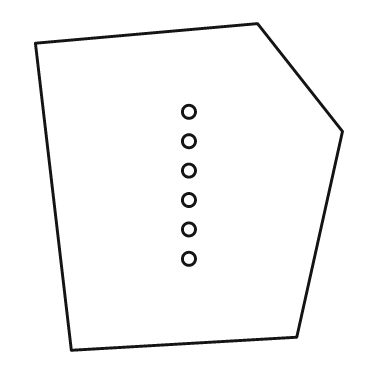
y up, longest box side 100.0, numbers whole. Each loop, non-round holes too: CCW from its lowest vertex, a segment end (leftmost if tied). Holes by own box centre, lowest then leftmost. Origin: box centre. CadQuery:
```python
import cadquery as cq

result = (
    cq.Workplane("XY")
    .moveTo(-36.0, -50.0)
    .lineTo(33.0, -46.0)
    .lineTo(47.0, 17.0)
    .lineTo(21.0, 50.0)
    .lineTo(-47.0, 44.0)
    .close()
    .moveTo(0.0, -22.0)
    .circle(2.0)
    .moveTo(0.0, -13.0)
    .circle(2.0)
    .moveTo(0.0, -4.0)
    .circle(2.0)
    .moveTo(0.0, 5.0)
    .circle(2.0)
    .moveTo(0.0, 14.0)
    .circle(2.0)
    .moveTo(0.0, 23.0)
    .circle(2.0)
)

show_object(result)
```